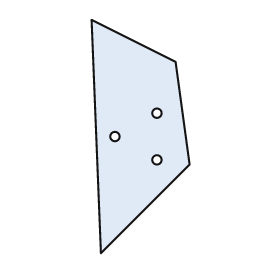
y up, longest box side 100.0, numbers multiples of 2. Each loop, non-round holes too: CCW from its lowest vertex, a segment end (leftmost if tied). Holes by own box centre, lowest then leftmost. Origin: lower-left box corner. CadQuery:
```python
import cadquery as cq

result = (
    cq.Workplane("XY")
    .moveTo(4.0, 0.0)
    .lineTo(42.0, 38.0)
    .lineTo(36.0, 82.0)
    .lineTo(0.0, 100.0)
    .close()
    .moveTo(28.0, 40.0)
    .circle(2.0)
    .moveTo(10.0, 50.0)
    .circle(2.0)
    .moveTo(28.0, 60.0)
    .circle(2.0)
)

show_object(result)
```